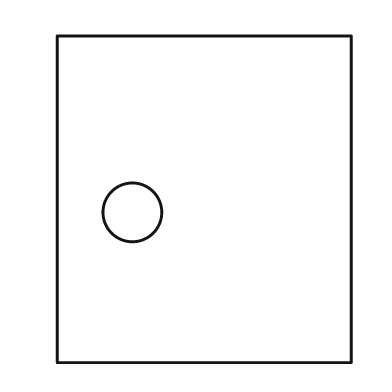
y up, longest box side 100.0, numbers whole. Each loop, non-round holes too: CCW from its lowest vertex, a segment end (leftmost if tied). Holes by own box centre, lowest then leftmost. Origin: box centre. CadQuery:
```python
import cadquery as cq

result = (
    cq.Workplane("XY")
    .moveTo(-45.0, -50.0)
    .lineTo(45.0, -50.0)
    .lineTo(45.0, 50.0)
    .lineTo(-45.0, 50.0)
    .close()
    .moveTo(-22.0, -4.0)
    .circle(9.0)
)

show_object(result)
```